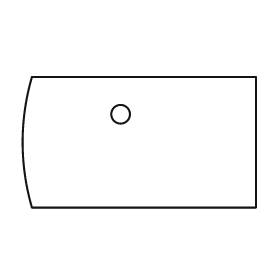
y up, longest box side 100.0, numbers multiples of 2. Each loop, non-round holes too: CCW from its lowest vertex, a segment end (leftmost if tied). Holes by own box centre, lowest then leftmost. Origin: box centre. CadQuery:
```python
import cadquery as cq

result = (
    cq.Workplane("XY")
    .moveTo(-46.0, -28.0)
    .lineTo(50.0, -28.0)
    .lineTo(50.0, 28.0)
    .lineTo(-46.0, 28.0)
    .threePointArc((-50.0, 0.0), (-46.0, -28.0))
    .close()
    .moveTo(-8.0, 12.0)
    .circle(4.0)
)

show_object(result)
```